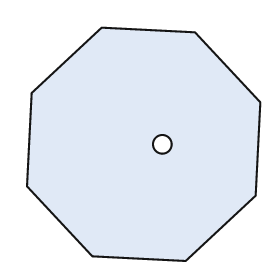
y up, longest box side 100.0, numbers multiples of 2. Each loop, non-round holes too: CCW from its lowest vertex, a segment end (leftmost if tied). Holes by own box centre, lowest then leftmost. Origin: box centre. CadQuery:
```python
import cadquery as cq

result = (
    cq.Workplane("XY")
    .moveTo(18.0, -50.0)
    .lineTo(48.0, -22.0)
    .lineTo(50.0, 18.0)
    .lineTo(22.0, 48.0)
    .lineTo(-18.0, 50.0)
    .lineTo(-48.0, 22.0)
    .lineTo(-50.0, -18.0)
    .lineTo(-22.0, -48.0)
    .close()
    .moveTo(8.0, 0.0)
    .circle(4.0)
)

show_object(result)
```